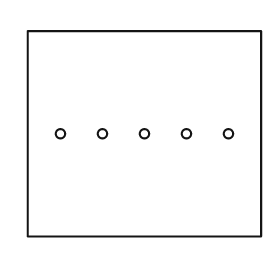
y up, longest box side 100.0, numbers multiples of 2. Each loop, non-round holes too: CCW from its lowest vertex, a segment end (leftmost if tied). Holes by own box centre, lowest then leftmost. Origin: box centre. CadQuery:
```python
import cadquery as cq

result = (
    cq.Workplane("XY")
    .moveTo(-50.0, -44.0)
    .lineTo(50.0, -44.0)
    .lineTo(50.0, 44.0)
    .lineTo(-50.0, 44.0)
    .close()
    .moveTo(-36.0, 0.0)
    .circle(2.0)
    .moveTo(-18.0, 0.0)
    .circle(2.0)
    .moveTo(0.0, 0.0)
    .circle(2.0)
    .moveTo(18.0, 0.0)
    .circle(2.0)
    .moveTo(36.0, 0.0)
    .circle(2.0)
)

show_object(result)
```